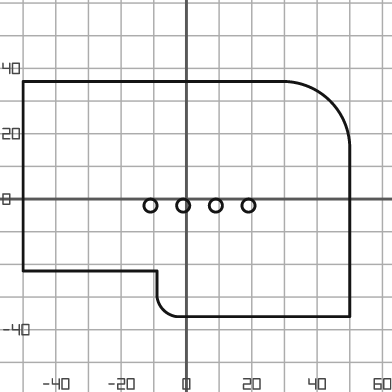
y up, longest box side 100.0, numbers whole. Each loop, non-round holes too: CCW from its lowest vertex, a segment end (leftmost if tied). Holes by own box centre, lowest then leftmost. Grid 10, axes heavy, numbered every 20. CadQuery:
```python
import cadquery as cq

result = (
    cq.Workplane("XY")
    .moveTo(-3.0, -36.0)
    .lineTo(50.0, -36.0)
    .lineTo(50.0, 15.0)
    .threePointArc((44.0, 30.0), (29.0, 36.0))
    .lineTo(-50.0, 36.0)
    .lineTo(-50.0, -22.0)
    .lineTo(-9.0, -22.0)
    .lineTo(-9.0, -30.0)
    .threePointArc((-7.0, -34.0), (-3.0, -36.0))
    .close()
    .moveTo(-11.0, -2.0)
    .circle(2.0)
    .moveTo(-1.0, -2.0)
    .circle(2.0)
    .moveTo(9.0, -2.0)
    .circle(2.0)
    .moveTo(19.0, -2.0)
    .circle(2.0)
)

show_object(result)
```